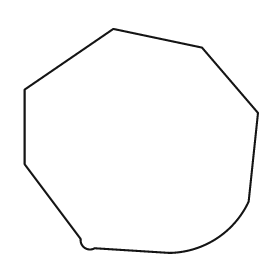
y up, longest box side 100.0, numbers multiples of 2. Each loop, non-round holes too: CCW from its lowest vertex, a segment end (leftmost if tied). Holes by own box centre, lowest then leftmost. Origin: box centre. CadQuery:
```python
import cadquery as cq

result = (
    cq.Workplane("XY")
    .moveTo(12.0, -48.0)
    .threePointArc((32.0, -42.0), (46.0, -26.0))
    .lineTo(50.0, 12.0)
    .lineTo(26.0, 40.0)
    .lineTo(-12.0, 48.0)
    .lineTo(-50.0, 22.0)
    .lineTo(-50.0, -10.0)
    .lineTo(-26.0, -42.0)
    .threePointArc((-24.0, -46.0), (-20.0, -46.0))
    .close()
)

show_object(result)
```